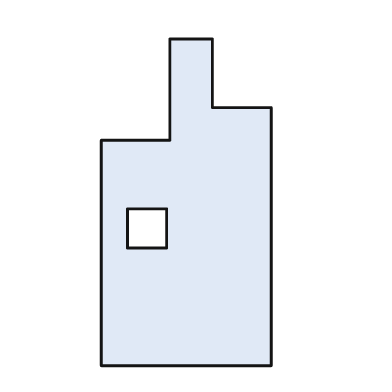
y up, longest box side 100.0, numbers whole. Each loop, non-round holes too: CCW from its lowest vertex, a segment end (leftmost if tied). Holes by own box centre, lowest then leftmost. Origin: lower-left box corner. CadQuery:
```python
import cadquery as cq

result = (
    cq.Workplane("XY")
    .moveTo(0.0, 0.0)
    .lineTo(52.0, 0.0)
    .lineTo(52.0, 79.0)
    .lineTo(34.0, 79.0)
    .lineTo(34.0, 100.0)
    .lineTo(21.0, 100.0)
    .lineTo(21.0, 69.0)
    .lineTo(0.0, 69.0)
    .close()
    .moveTo(8.0, 36.0)
    .lineTo(20.0, 36.0)
    .lineTo(20.0, 48.0)
    .lineTo(8.0, 48.0)
    .close()
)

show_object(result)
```